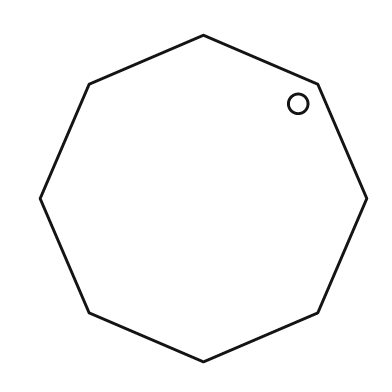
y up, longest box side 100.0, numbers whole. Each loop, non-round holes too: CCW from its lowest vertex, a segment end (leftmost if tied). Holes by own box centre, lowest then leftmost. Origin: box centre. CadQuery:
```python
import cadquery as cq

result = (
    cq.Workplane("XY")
    .moveTo(0.0, -50.0)
    .lineTo(35.0, -35.0)
    .lineTo(50.0, 0.0)
    .lineTo(35.0, 35.0)
    .lineTo(0.0, 50.0)
    .lineTo(-35.0, 35.0)
    .lineTo(-50.0, 0.0)
    .lineTo(-35.0, -35.0)
    .close()
    .moveTo(29.0, 29.0)
    .circle(3.0)
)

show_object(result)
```